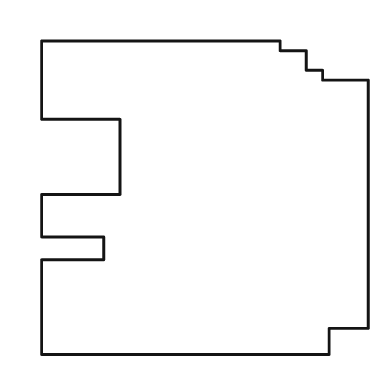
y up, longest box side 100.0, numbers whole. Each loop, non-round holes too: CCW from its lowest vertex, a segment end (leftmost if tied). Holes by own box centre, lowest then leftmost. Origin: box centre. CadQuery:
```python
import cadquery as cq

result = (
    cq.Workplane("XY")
    .moveTo(-50.0, -48.0)
    .lineTo(38.0, -48.0)
    .lineTo(38.0, -40.0)
    .lineTo(50.0, -40.0)
    .lineTo(50.0, 36.0)
    .lineTo(36.0, 36.0)
    .lineTo(36.0, 39.0)
    .lineTo(31.0, 39.0)
    .lineTo(31.0, 45.0)
    .lineTo(23.0, 45.0)
    .lineTo(23.0, 48.0)
    .lineTo(-50.0, 48.0)
    .lineTo(-50.0, 24.0)
    .lineTo(-26.0, 24.0)
    .lineTo(-26.0, 1.0)
    .lineTo(-50.0, 1.0)
    .lineTo(-50.0, -12.0)
    .lineTo(-31.0, -12.0)
    .lineTo(-31.0, -19.0)
    .lineTo(-50.0, -19.0)
    .close()
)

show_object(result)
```